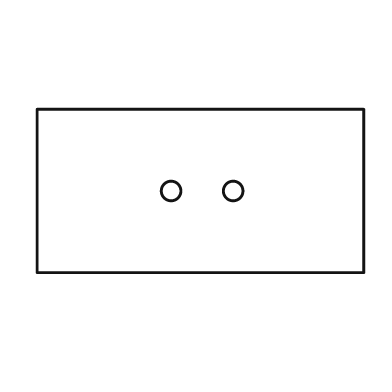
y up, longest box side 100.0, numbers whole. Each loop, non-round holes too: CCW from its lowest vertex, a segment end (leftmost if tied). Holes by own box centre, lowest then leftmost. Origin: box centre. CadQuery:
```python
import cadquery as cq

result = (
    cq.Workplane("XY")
    .moveTo(-50.0, -25.0)
    .lineTo(50.0, -25.0)
    .lineTo(50.0, 25.0)
    .lineTo(-50.0, 25.0)
    .close()
    .moveTo(-9.0, 0.0)
    .circle(3.0)
    .moveTo(10.0, 0.0)
    .circle(3.0)
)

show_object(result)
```